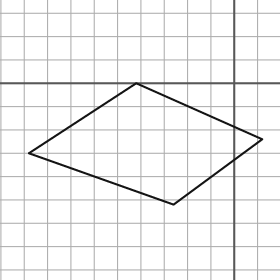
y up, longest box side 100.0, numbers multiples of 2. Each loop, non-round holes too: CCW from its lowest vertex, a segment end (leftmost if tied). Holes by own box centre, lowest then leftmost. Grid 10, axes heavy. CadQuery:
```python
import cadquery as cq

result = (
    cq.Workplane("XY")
    .moveTo(-26.0, -52.0)
    .lineTo(12.0, -24.0)
    .lineTo(-42.0, 0.0)
    .lineTo(-88.0, -30.0)
    .close()
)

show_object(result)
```